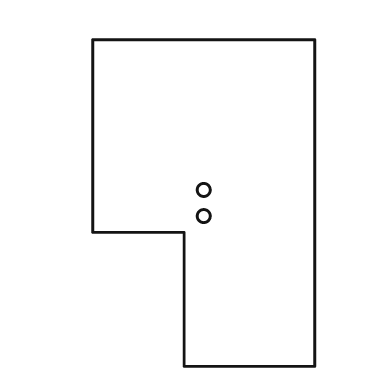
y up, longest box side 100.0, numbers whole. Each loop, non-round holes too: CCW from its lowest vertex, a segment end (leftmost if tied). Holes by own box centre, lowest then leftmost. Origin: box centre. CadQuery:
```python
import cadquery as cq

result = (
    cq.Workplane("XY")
    .moveTo(-6.0, -50.0)
    .lineTo(34.0, -50.0)
    .lineTo(34.0, 50.0)
    .lineTo(-34.0, 50.0)
    .lineTo(-34.0, -9.0)
    .lineTo(-6.0, -9.0)
    .close()
    .moveTo(0.0, -4.0)
    .circle(2.0)
    .moveTo(0.0, 4.0)
    .circle(2.0)
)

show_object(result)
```